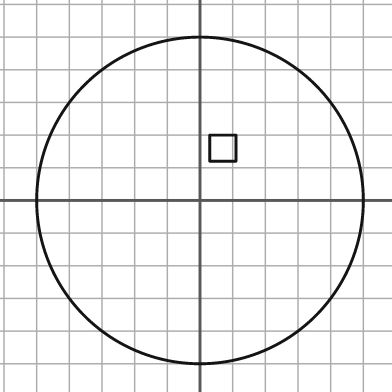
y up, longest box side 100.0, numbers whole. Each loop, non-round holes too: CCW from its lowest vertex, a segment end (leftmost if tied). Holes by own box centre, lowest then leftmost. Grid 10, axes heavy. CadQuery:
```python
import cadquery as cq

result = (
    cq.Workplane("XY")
    .moveTo(0.0, 0.0)
    .circle(50.0)
    .moveTo(3.0, 12.0)
    .lineTo(11.0, 12.0)
    .lineTo(11.0, 20.0)
    .lineTo(3.0, 20.0)
    .close()
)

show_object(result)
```